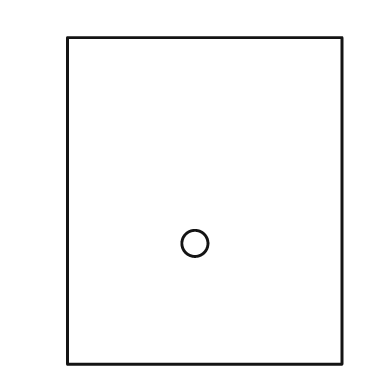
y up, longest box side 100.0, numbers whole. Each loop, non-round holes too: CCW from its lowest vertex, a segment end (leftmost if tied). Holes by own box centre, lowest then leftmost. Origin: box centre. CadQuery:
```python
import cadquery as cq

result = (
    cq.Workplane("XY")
    .moveTo(-42.0, -50.0)
    .lineTo(42.0, -50.0)
    .lineTo(42.0, 50.0)
    .lineTo(-42.0, 50.0)
    .close()
    .moveTo(-3.0, -13.0)
    .circle(4.0)
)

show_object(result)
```